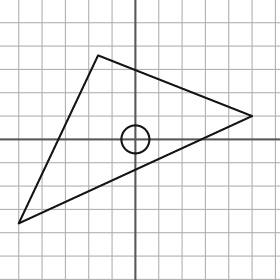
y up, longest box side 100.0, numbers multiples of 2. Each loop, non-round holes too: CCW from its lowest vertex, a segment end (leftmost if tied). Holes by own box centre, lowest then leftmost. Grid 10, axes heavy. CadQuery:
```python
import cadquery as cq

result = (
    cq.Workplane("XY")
    .moveTo(-50.0, -36.0)
    .lineTo(50.0, 10.0)
    .lineTo(-16.0, 36.0)
    .close()
    .moveTo(0.0, 0.0)
    .circle(6.0)
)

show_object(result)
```